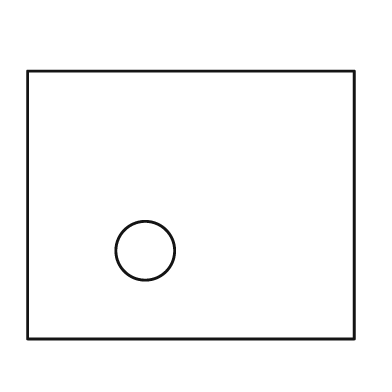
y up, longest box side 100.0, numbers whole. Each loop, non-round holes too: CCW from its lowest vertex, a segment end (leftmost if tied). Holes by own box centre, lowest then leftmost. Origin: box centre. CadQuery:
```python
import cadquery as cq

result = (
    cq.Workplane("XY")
    .moveTo(-50.0, -41.0)
    .lineTo(50.0, -41.0)
    .lineTo(50.0, 41.0)
    .lineTo(-50.0, 41.0)
    .close()
    .moveTo(-14.0, -14.0)
    .circle(9.0)
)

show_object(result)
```